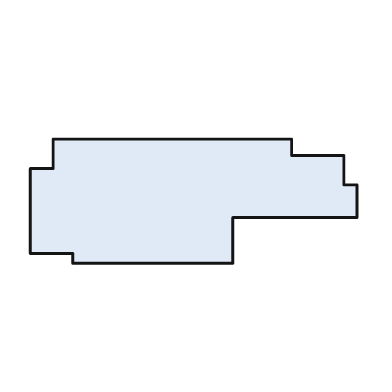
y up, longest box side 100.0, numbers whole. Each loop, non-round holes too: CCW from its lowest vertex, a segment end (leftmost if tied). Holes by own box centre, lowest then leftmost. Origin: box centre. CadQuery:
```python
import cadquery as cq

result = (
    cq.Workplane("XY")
    .moveTo(-37.0, -19.0)
    .lineTo(12.0, -19.0)
    .lineTo(12.0, -5.0)
    .lineTo(50.0, -5.0)
    .lineTo(50.0, 5.0)
    .lineTo(46.0, 5.0)
    .lineTo(46.0, 14.0)
    .lineTo(30.0, 14.0)
    .lineTo(30.0, 19.0)
    .lineTo(-43.0, 19.0)
    .lineTo(-43.0, 10.0)
    .lineTo(-50.0, 10.0)
    .lineTo(-50.0, -16.0)
    .lineTo(-37.0, -16.0)
    .close()
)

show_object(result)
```